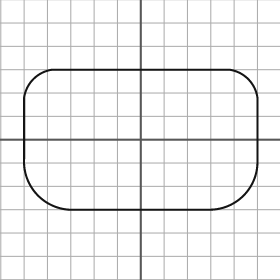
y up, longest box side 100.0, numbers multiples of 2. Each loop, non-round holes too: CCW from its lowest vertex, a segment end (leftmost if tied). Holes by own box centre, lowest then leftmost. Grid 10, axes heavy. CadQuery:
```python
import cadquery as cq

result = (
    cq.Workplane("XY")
    .moveTo(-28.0, -30.0)
    .lineTo(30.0, -30.0)
    .threePointArc((44.0, -24.0), (50.0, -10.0))
    .lineTo(50.0, 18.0)
    .threePointArc((46.0, 26.0), (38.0, 30.0))
    .lineTo(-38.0, 30.0)
    .threePointArc((-46.0, 26.0), (-50.0, 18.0))
    .lineTo(-50.0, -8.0)
    .threePointArc((-44.0, -24.0), (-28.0, -30.0))
    .close()
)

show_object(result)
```